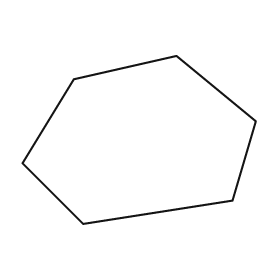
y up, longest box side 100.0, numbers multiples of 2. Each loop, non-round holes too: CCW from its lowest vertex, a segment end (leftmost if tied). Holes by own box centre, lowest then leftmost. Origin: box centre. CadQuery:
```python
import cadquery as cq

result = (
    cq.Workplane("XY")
    .moveTo(-24.0, -36.0)
    .lineTo(40.0, -26.0)
    .lineTo(50.0, 8.0)
    .lineTo(16.0, 36.0)
    .lineTo(-28.0, 26.0)
    .lineTo(-50.0, -10.0)
    .close()
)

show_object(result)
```